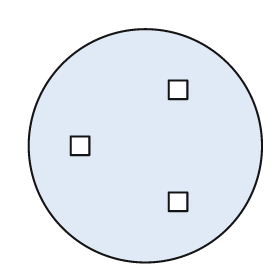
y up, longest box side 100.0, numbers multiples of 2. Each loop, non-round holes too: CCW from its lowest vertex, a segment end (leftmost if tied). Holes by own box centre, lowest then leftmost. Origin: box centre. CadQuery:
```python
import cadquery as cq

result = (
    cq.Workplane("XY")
    .moveTo(0.0, 0.0)
    .circle(50.0)
    .moveTo(10.0, -28.0)
    .lineTo(18.0, -28.0)
    .lineTo(18.0, -20.0)
    .lineTo(10.0, -20.0)
    .close()
    .moveTo(-32.0, -4.0)
    .lineTo(-24.0, -4.0)
    .lineTo(-24.0, 4.0)
    .lineTo(-32.0, 4.0)
    .close()
    .moveTo(10.0, 20.0)
    .lineTo(18.0, 20.0)
    .lineTo(18.0, 28.0)
    .lineTo(10.0, 28.0)
    .close()
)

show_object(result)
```